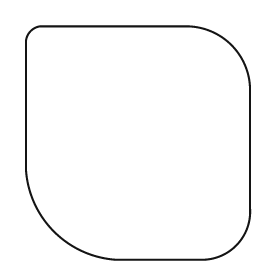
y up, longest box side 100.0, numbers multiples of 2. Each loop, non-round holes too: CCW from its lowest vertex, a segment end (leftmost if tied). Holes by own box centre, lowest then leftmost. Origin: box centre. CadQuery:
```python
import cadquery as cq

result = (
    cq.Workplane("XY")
    .moveTo(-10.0, -50.0)
    .lineTo(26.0, -50.0)
    .threePointArc((42.0, -44.0), (48.0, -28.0))
    .lineTo(48.0, 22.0)
    .threePointArc((40.0, 42.0), (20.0, 50.0))
    .lineTo(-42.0, 50.0)
    .threePointArc((-46.0, 48.0), (-48.0, 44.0))
    .lineTo(-48.0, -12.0)
    .threePointArc((-36.0, -38.0), (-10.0, -50.0))
    .close()
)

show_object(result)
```